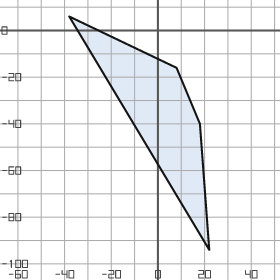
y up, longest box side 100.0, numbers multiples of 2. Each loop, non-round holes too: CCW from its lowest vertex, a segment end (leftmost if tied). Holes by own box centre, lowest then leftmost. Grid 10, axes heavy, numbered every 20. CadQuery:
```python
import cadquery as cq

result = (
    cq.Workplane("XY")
    .moveTo(22.0, -94.0)
    .lineTo(18.0, -40.0)
    .lineTo(8.0, -16.0)
    .lineTo(-38.0, 6.0)
    .close()
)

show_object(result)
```